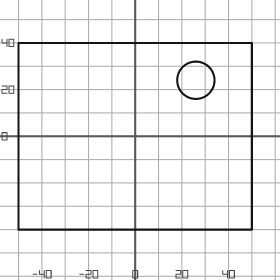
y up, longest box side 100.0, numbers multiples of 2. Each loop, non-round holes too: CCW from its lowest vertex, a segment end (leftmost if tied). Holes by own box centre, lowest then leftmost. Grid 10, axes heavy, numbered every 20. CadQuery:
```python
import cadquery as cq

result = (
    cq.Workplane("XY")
    .moveTo(-50.0, -40.0)
    .lineTo(50.0, -40.0)
    .lineTo(50.0, 40.0)
    .lineTo(-50.0, 40.0)
    .close()
    .moveTo(26.0, 24.0)
    .circle(8.0)
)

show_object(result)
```